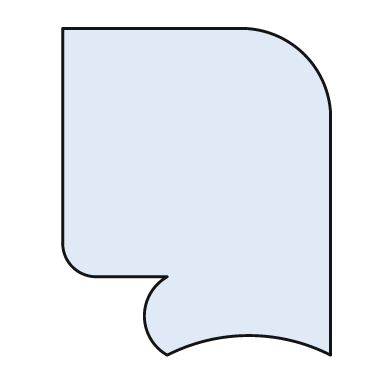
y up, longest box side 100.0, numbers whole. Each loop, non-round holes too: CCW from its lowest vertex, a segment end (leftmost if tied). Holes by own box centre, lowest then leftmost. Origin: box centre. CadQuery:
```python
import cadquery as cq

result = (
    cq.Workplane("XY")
    .moveTo(-9.0, -50.0)
    .threePointArc((16.0, -44.0), (41.0, -50.0))
    .lineTo(41.0, 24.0)
    .threePointArc((33.0, 42.0), (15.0, 50.0))
    .lineTo(-41.0, 50.0)
    .lineTo(-41.0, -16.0)
    .threePointArc((-38.0, -23.0), (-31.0, -26.0))
    .lineTo(-9.0, -26.0)
    .threePointArc((-16.0, -38.0), (-9.0, -50.0))
    .close()
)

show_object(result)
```